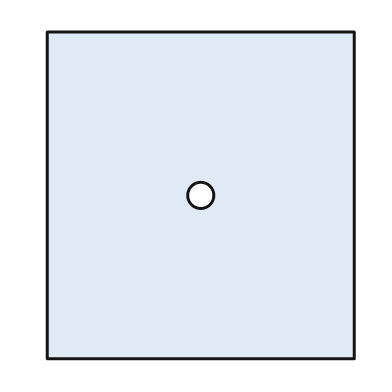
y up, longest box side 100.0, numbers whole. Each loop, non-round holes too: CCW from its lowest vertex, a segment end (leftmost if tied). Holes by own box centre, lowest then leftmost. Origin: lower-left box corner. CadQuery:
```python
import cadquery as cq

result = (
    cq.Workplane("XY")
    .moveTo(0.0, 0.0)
    .lineTo(94.0, 0.0)
    .lineTo(94.0, 100.0)
    .lineTo(0.0, 100.0)
    .close()
    .moveTo(47.0, 50.0)
    .circle(4.0)
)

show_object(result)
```